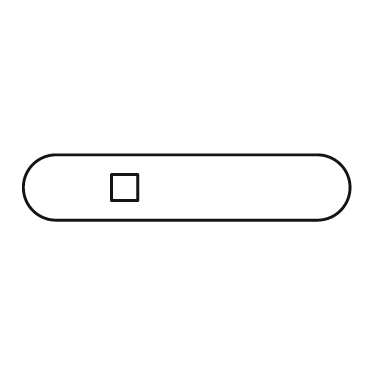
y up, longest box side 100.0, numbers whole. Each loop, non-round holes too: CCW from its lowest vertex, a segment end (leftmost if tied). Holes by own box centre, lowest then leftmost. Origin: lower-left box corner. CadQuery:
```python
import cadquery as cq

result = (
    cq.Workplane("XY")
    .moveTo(10.0, 0.0)
    .lineTo(90.0, 0.0)
    .threePointArc((100.0, 10.0), (90.0, 20.0))
    .lineTo(10.0, 20.0)
    .threePointArc((0.0, 10.0), (10.0, 0.0))
    .close()
    .moveTo(27.0, 6.0)
    .lineTo(35.0, 6.0)
    .lineTo(35.0, 14.0)
    .lineTo(27.0, 14.0)
    .close()
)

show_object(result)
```